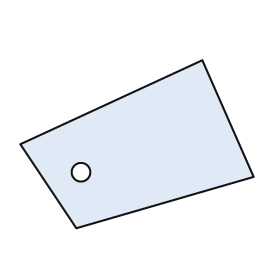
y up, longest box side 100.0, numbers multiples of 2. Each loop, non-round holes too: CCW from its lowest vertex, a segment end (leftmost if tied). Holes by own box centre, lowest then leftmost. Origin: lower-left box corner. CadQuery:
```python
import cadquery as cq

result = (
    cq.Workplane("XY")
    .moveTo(24.0, 0.0)
    .lineTo(100.0, 22.0)
    .lineTo(78.0, 72.0)
    .lineTo(0.0, 36.0)
    .close()
    .moveTo(26.0, 24.0)
    .circle(4.0)
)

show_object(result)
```